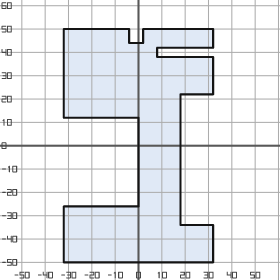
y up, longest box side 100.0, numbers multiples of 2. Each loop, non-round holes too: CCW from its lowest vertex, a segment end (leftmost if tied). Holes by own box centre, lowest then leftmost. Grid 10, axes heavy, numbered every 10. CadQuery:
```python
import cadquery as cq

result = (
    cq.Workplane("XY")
    .moveTo(-32.0, -50.0)
    .lineTo(32.0, -50.0)
    .lineTo(32.0, -34.0)
    .lineTo(18.0, -34.0)
    .lineTo(18.0, 22.0)
    .lineTo(32.0, 22.0)
    .lineTo(32.0, 38.0)
    .lineTo(8.0, 38.0)
    .lineTo(8.0, 42.0)
    .lineTo(32.0, 42.0)
    .lineTo(32.0, 50.0)
    .lineTo(2.0, 50.0)
    .lineTo(2.0, 44.0)
    .lineTo(-4.0, 44.0)
    .lineTo(-4.0, 50.0)
    .lineTo(-32.0, 50.0)
    .lineTo(-32.0, 12.0)
    .lineTo(0.0, 12.0)
    .lineTo(0.0, -26.0)
    .lineTo(-32.0, -26.0)
    .close()
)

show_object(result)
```